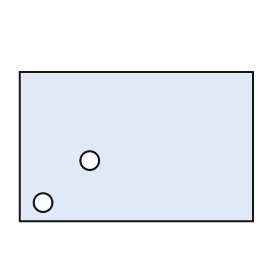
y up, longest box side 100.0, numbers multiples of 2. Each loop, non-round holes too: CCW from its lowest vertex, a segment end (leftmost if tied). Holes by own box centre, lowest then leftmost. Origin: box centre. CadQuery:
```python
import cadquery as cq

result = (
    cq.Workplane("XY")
    .moveTo(-50.0, -32.0)
    .lineTo(50.0, -32.0)
    .lineTo(50.0, 32.0)
    .lineTo(-50.0, 32.0)
    .close()
    .moveTo(-40.0, -24.0)
    .circle(4.0)
    .moveTo(-20.0, -6.0)
    .circle(4.0)
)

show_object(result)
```